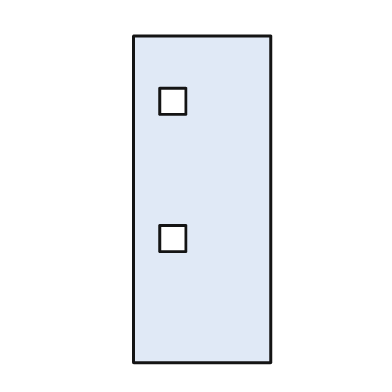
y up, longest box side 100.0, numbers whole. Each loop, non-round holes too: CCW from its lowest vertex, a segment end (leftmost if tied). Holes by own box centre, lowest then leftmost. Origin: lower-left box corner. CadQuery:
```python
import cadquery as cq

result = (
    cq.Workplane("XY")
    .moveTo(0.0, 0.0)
    .lineTo(42.0, 0.0)
    .lineTo(42.0, 100.0)
    .lineTo(0.0, 100.0)
    .close()
    .moveTo(8.0, 34.0)
    .lineTo(16.0, 34.0)
    .lineTo(16.0, 42.0)
    .lineTo(8.0, 42.0)
    .close()
    .moveTo(8.0, 76.0)
    .lineTo(16.0, 76.0)
    .lineTo(16.0, 84.0)
    .lineTo(8.0, 84.0)
    .close()
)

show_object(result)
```